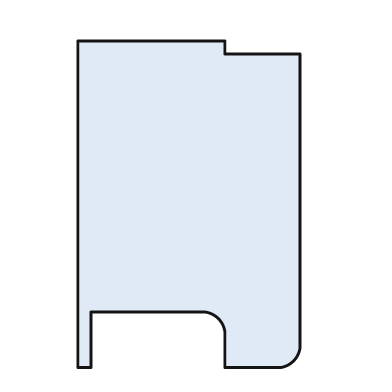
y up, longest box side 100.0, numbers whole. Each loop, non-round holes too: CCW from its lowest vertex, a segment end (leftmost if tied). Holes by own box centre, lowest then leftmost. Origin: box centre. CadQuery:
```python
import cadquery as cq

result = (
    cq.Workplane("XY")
    .moveTo(-34.0, -50.0)
    .lineTo(-30.0, -50.0)
    .lineTo(-30.0, -33.0)
    .lineTo(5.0, -33.0)
    .threePointArc((9.0, -35.0), (11.0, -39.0))
    .lineTo(11.0, -50.0)
    .lineTo(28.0, -50.0)
    .threePointArc((32.0, -48.0), (34.0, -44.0))
    .lineTo(34.0, 46.0)
    .lineTo(11.0, 46.0)
    .lineTo(11.0, 50.0)
    .lineTo(-34.0, 50.0)
    .close()
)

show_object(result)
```